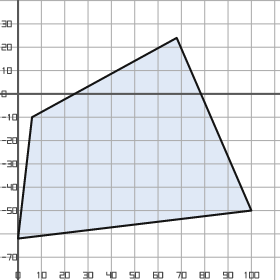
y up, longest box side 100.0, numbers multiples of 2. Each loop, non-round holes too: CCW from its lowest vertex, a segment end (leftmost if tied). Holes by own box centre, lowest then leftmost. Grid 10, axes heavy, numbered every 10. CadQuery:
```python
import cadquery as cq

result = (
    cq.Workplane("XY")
    .moveTo(0.0, -62.0)
    .lineTo(100.0, -50.0)
    .lineTo(68.0, 24.0)
    .lineTo(6.0, -10.0)
    .close()
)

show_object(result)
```